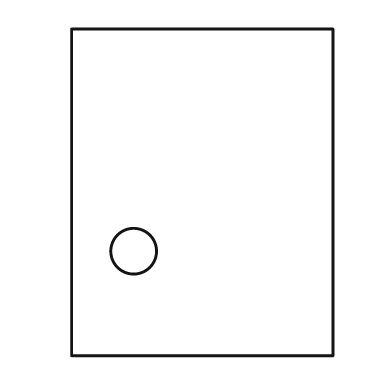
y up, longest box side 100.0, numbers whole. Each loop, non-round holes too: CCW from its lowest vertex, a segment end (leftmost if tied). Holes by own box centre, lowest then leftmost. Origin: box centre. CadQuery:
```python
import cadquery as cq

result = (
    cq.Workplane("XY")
    .moveTo(-40.0, -50.0)
    .lineTo(40.0, -50.0)
    .lineTo(40.0, 50.0)
    .lineTo(-40.0, 50.0)
    .close()
    .moveTo(-21.0, -18.0)
    .circle(7.0)
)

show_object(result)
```